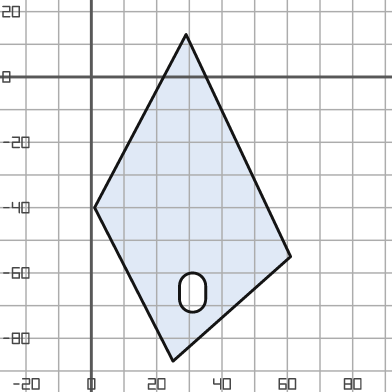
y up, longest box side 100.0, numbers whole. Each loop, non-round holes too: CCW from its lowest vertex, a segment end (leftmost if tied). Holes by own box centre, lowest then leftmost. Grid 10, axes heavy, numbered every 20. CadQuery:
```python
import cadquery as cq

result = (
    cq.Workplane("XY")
    .moveTo(25.0, -87.0)
    .lineTo(61.0, -55.0)
    .lineTo(29.0, 13.0)
    .lineTo(1.0, -40.0)
    .close()
    .moveTo(27.0, -68.0)
    .threePointArc((31.0, -72.0), (35.0, -68.0))
    .lineTo(35.0, -64.0)
    .threePointArc((31.0, -60.0), (27.0, -64.0))
    .close()
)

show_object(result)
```